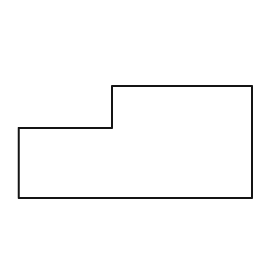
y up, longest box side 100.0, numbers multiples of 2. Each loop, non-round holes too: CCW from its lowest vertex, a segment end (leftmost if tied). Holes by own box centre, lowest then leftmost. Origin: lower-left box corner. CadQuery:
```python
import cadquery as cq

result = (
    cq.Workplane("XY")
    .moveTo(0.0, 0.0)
    .lineTo(100.0, 0.0)
    .lineTo(100.0, 48.0)
    .lineTo(40.0, 48.0)
    .lineTo(40.0, 30.0)
    .lineTo(0.0, 30.0)
    .close()
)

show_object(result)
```